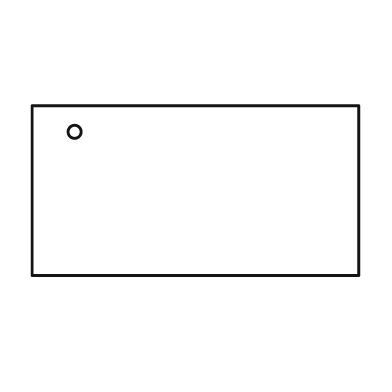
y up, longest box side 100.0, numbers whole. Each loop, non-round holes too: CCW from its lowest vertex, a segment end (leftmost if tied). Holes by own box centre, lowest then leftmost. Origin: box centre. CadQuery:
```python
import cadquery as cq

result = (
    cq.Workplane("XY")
    .moveTo(-50.0, -26.0)
    .lineTo(50.0, -26.0)
    .lineTo(50.0, 26.0)
    .lineTo(-50.0, 26.0)
    .close()
    .moveTo(-37.0, 18.0)
    .circle(2.0)
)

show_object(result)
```